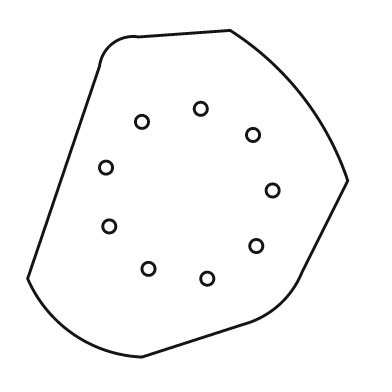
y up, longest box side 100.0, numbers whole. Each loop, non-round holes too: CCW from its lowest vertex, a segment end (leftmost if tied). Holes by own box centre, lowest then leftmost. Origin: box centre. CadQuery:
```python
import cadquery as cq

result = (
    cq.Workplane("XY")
    .moveTo(-14.0, -50.0)
    .lineTo(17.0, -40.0)
    .threePointArc((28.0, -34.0), (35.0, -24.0))
    .lineTo(49.0, 4.0)
    .threePointArc((35.0, 30.0), (13.0, 50.0))
    .lineTo(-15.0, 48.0)
    .threePointArc((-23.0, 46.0), (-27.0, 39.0))
    .lineTo(-49.0, -26.0)
    .threePointArc((-35.0, -43.0), (-14.0, -50.0))
    .close()
    .moveTo(6.0, -26.0)
    .circle(2.0)
    .moveTo(-12.0, -23.0)
    .circle(2.0)
    .moveTo(21.0, -16.0)
    .circle(2.0)
    .moveTo(-24.0, -10.0)
    .circle(2.0)
    .moveTo(26.0, 1.0)
    .circle(2.0)
    .moveTo(-25.0, 8.0)
    .circle(2.0)
    .moveTo(20.0, 18.0)
    .circle(2.0)
    .moveTo(-14.0, 22.0)
    .circle(2.0)
    .moveTo(4.0, 26.0)
    .circle(2.0)
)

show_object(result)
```